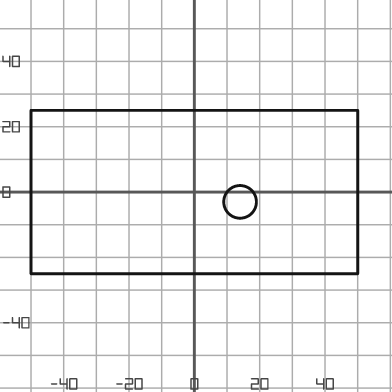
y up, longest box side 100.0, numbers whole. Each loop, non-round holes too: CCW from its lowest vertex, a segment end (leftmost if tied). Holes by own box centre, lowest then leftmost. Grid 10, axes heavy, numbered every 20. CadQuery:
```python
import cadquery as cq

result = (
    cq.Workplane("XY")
    .moveTo(-50.0, -25.0)
    .lineTo(50.0, -25.0)
    .lineTo(50.0, 25.0)
    .lineTo(-50.0, 25.0)
    .close()
    .moveTo(14.0, -3.0)
    .circle(5.0)
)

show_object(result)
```